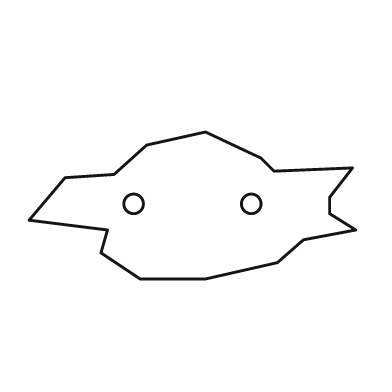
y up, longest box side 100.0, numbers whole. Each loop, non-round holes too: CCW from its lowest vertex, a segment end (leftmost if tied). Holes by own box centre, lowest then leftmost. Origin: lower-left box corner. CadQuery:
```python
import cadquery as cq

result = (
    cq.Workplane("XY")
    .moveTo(34.0, 0.0)
    .lineTo(54.0, 0.0)
    .lineTo(76.0, 5.0)
    .lineTo(84.0, 12.0)
    .lineTo(100.0, 15.0)
    .lineTo(92.0, 20.0)
    .lineTo(92.0, 25.0)
    .lineTo(99.0, 34.0)
    .lineTo(75.0, 33.0)
    .lineTo(71.0, 37.0)
    .lineTo(54.0, 45.0)
    .lineTo(36.0, 41.0)
    .lineTo(26.0, 32.0)
    .lineTo(11.0, 31.0)
    .lineTo(0.0, 18.0)
    .lineTo(24.0, 15.0)
    .lineTo(22.0, 8.0)
    .close()
    .moveTo(32.0, 23.0)
    .circle(3.0)
    .moveTo(68.0, 23.0)
    .circle(3.0)
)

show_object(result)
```